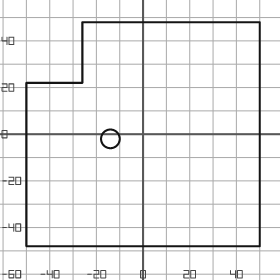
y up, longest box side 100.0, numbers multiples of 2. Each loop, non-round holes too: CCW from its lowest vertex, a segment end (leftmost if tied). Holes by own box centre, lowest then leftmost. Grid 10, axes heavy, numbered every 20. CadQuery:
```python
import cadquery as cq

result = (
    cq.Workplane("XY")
    .moveTo(-50.0, -48.0)
    .lineTo(50.0, -48.0)
    .lineTo(50.0, 48.0)
    .lineTo(-26.0, 48.0)
    .lineTo(-26.0, 22.0)
    .lineTo(-50.0, 22.0)
    .close()
    .moveTo(-14.0, -2.0)
    .circle(4.0)
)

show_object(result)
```